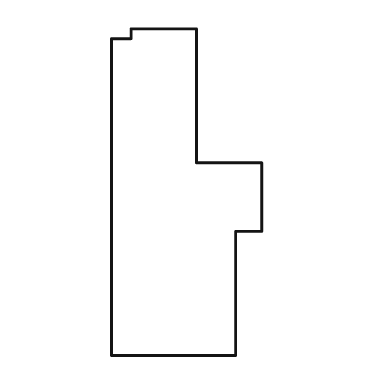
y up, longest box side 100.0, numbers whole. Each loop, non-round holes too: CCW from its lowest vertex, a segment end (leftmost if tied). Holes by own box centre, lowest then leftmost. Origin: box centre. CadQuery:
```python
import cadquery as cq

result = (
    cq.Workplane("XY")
    .moveTo(-23.0, -50.0)
    .lineTo(15.0, -50.0)
    .lineTo(15.0, -12.0)
    .lineTo(23.0, -12.0)
    .lineTo(23.0, 9.0)
    .lineTo(3.0, 9.0)
    .lineTo(3.0, 50.0)
    .lineTo(-17.0, 50.0)
    .lineTo(-17.0, 47.0)
    .lineTo(-23.0, 47.0)
    .close()
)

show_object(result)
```